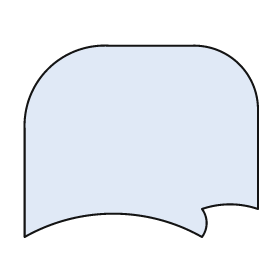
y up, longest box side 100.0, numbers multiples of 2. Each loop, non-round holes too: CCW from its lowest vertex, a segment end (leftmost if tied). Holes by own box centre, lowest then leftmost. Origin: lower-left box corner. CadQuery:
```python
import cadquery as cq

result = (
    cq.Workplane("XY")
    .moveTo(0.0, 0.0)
    .threePointArc((38.0, 10.0), (76.0, 0.0))
    .threePointArc((78.0, 6.0), (76.0, 12.0))
    .threePointArc((88.0, 14.0), (100.0, 12.0))
    .lineTo(100.0, 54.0)
    .threePointArc((92.0, 74.0), (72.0, 82.0))
    .lineTo(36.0, 82.0)
    .threePointArc((10.0, 72.0), (0.0, 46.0))
    .close()
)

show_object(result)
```